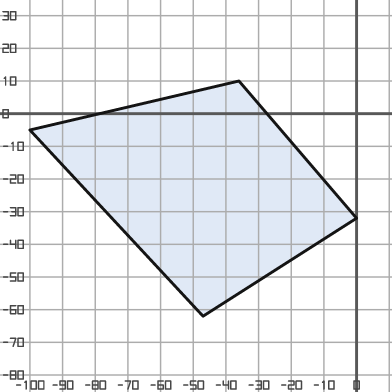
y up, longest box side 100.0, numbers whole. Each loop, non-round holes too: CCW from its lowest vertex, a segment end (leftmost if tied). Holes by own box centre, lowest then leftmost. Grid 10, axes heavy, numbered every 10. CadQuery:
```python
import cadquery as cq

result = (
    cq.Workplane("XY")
    .moveTo(-47.0, -62.0)
    .lineTo(0.0, -32.0)
    .lineTo(-36.0, 10.0)
    .lineTo(-100.0, -5.0)
    .close()
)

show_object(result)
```